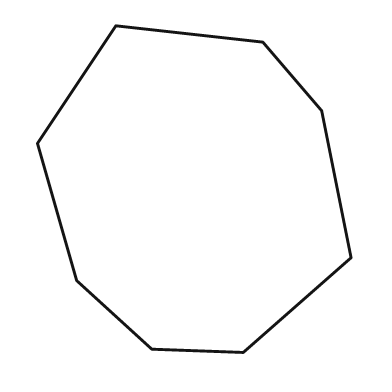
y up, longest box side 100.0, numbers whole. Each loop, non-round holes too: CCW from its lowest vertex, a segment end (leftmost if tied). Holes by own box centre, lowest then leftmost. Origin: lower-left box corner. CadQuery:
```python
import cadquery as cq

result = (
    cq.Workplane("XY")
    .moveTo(63.0, 0.0)
    .lineTo(96.0, 29.0)
    .lineTo(87.0, 74.0)
    .lineTo(69.0, 95.0)
    .lineTo(24.0, 100.0)
    .lineTo(0.0, 64.0)
    .lineTo(12.0, 22.0)
    .lineTo(35.0, 1.0)
    .close()
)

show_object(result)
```